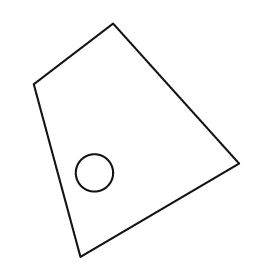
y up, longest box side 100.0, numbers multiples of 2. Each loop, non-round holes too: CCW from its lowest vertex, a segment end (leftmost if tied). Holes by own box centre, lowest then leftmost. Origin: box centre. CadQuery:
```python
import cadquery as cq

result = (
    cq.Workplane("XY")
    .moveTo(-24.0, -50.0)
    .lineTo(44.0, -10.0)
    .lineTo(-10.0, 50.0)
    .lineTo(-44.0, 24.0)
    .close()
    .moveTo(-18.0, -14.0)
    .circle(8.0)
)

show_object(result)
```